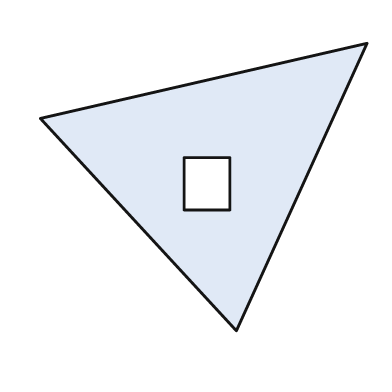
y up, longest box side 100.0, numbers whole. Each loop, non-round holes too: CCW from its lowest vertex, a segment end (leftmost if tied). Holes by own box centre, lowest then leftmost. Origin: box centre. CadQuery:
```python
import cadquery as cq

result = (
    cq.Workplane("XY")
    .moveTo(10.0, -44.0)
    .lineTo(50.0, 44.0)
    .lineTo(-50.0, 21.0)
    .close()
    .moveTo(-6.0, -7.0)
    .lineTo(8.0, -7.0)
    .lineTo(8.0, 9.0)
    .lineTo(-6.0, 9.0)
    .close()
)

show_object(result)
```